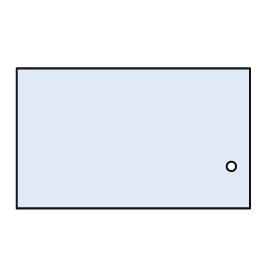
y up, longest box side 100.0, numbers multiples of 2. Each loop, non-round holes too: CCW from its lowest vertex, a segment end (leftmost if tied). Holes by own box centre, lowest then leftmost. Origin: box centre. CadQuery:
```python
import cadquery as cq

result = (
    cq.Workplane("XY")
    .moveTo(-50.0, -30.0)
    .lineTo(50.0, -30.0)
    .lineTo(50.0, 30.0)
    .lineTo(-50.0, 30.0)
    .close()
    .moveTo(42.0, -12.0)
    .circle(2.0)
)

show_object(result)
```